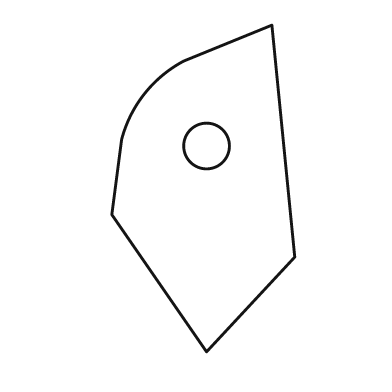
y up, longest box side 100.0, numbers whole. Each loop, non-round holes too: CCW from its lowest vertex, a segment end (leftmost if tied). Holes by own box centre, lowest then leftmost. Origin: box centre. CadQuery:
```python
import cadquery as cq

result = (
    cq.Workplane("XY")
    .moveTo(1.0, -50.0)
    .lineTo(28.0, -21.0)
    .lineTo(21.0, 50.0)
    .lineTo(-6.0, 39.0)
    .threePointArc((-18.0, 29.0), (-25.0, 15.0))
    .lineTo(-28.0, -8.0)
    .close()
    .moveTo(1.0, 13.0)
    .circle(7.0)
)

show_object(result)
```